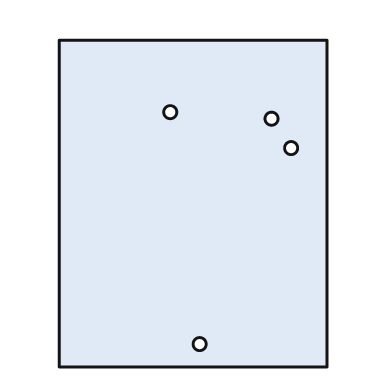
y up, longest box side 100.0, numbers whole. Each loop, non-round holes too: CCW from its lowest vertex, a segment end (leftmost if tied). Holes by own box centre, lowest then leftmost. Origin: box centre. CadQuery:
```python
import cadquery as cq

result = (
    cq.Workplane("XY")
    .moveTo(-41.0, -50.0)
    .lineTo(41.0, -50.0)
    .lineTo(41.0, 50.0)
    .lineTo(-41.0, 50.0)
    .close()
    .moveTo(2.0, -43.0)
    .circle(2.0)
    .moveTo(30.0, 17.0)
    .circle(2.0)
    .moveTo(24.0, 26.0)
    .circle(2.0)
    .moveTo(-7.0, 28.0)
    .circle(2.0)
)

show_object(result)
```